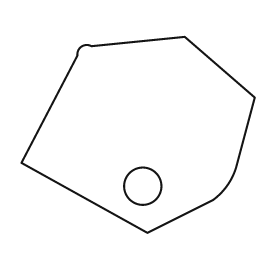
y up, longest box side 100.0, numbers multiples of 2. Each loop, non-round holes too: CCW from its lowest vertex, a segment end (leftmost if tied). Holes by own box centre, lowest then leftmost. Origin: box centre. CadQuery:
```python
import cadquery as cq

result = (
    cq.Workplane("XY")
    .moveTo(4.0, -42.0)
    .lineTo(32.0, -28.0)
    .threePointArc((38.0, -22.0), (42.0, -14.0))
    .lineTo(50.0, 16.0)
    .lineTo(20.0, 42.0)
    .lineTo(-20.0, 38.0)
    .threePointArc((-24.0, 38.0), (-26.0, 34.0))
    .lineTo(-50.0, -12.0)
    .close()
    .moveTo(2.0, -22.0)
    .circle(8.0)
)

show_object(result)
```